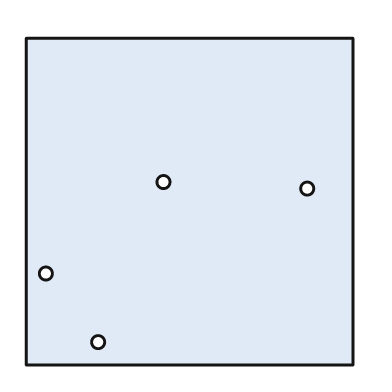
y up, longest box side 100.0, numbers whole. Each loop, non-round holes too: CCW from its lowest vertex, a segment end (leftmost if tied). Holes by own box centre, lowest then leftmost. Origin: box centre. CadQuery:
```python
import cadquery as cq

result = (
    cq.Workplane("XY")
    .moveTo(-50.0, -50.0)
    .lineTo(50.0, -50.0)
    .lineTo(50.0, 50.0)
    .lineTo(-50.0, 50.0)
    .close()
    .moveTo(-28.0, -43.0)
    .circle(2.0)
    .moveTo(-44.0, -22.0)
    .circle(2.0)
    .moveTo(36.0, 4.0)
    .circle(2.0)
    .moveTo(-8.0, 6.0)
    .circle(2.0)
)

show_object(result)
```